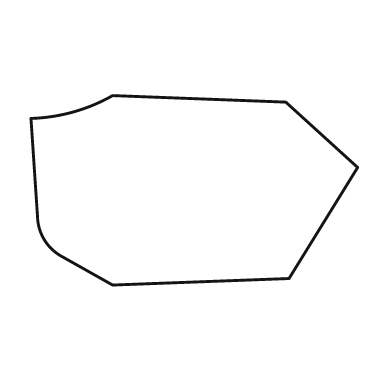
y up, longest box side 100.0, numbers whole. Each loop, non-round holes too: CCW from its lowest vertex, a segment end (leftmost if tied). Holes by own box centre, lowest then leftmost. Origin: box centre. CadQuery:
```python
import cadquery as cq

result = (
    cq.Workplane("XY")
    .moveTo(-25.0, -29.0)
    .lineTo(29.0, -27.0)
    .lineTo(50.0, 7.0)
    .lineTo(28.0, 27.0)
    .lineTo(-25.0, 29.0)
    .threePointArc((-37.0, 24.0), (-50.0, 22.0))
    .lineTo(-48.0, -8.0)
    .threePointArc((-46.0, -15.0), (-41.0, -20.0))
    .close()
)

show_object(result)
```